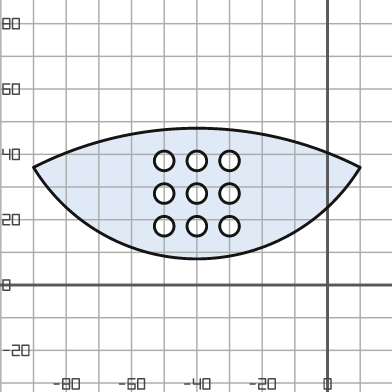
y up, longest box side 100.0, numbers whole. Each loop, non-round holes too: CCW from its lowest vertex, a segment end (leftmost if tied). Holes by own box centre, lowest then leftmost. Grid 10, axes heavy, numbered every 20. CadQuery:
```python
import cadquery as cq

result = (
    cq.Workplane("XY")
    .moveTo(-90.0, 36.0)
    .threePointArc((-40.0, 8.0), (10.0, 36.0))
    .threePointArc((-40.0, 48.0), (-90.0, 36.0))
    .close()
    .moveTo(-50.0, 18.0)
    .circle(3.0)
    .moveTo(-40.0, 18.0)
    .circle(3.0)
    .moveTo(-30.0, 18.0)
    .circle(3.0)
    .moveTo(-50.0, 28.0)
    .circle(3.0)
    .moveTo(-40.0, 28.0)
    .circle(3.0)
    .moveTo(-30.0, 28.0)
    .circle(3.0)
    .moveTo(-50.0, 38.0)
    .circle(3.0)
    .moveTo(-40.0, 38.0)
    .circle(3.0)
    .moveTo(-30.0, 38.0)
    .circle(3.0)
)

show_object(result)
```